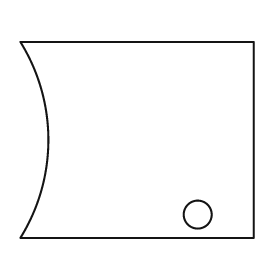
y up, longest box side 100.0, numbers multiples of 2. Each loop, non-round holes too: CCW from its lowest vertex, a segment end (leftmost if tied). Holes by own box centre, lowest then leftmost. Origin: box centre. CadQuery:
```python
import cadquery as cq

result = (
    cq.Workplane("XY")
    .moveTo(-50.0, -42.0)
    .lineTo(50.0, -42.0)
    .lineTo(50.0, 42.0)
    .lineTo(-50.0, 42.0)
    .threePointArc((-38.0, 0.0), (-50.0, -42.0))
    .close()
    .moveTo(26.0, -32.0)
    .circle(6.0)
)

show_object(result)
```